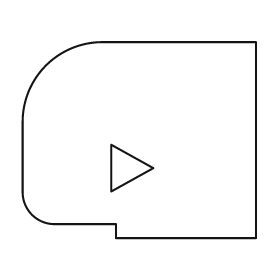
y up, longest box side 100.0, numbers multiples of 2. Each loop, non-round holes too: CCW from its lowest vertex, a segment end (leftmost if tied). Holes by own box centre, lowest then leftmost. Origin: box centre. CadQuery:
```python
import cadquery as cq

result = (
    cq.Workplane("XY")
    .moveTo(-10.0, -42.0)
    .lineTo(50.0, -42.0)
    .lineTo(50.0, 42.0)
    .lineTo(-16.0, 42.0)
    .threePointArc((-40.0, 32.0), (-50.0, 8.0))
    .lineTo(-50.0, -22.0)
    .threePointArc((-46.0, -32.0), (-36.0, -36.0))
    .lineTo(-10.0, -36.0)
    .close()
    .moveTo(-12.0, -22.0)
    .lineTo(6.0, -12.0)
    .lineTo(-12.0, -2.0)
    .close()
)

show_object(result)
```